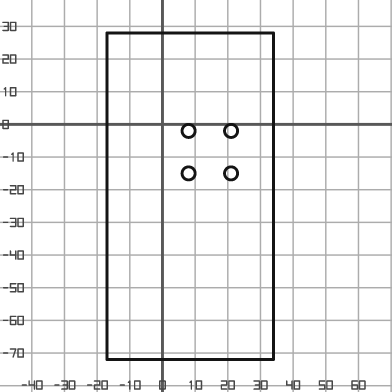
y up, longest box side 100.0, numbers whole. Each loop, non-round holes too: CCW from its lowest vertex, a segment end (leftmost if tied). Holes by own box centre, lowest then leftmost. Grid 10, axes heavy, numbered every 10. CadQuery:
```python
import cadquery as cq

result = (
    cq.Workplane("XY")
    .moveTo(-17.0, -72.0)
    .lineTo(34.0, -72.0)
    .lineTo(34.0, 28.0)
    .lineTo(-17.0, 28.0)
    .close()
    .moveTo(8.0, -15.0)
    .circle(2.0)
    .moveTo(21.0, -15.0)
    .circle(2.0)
    .moveTo(8.0, -2.0)
    .circle(2.0)
    .moveTo(21.0, -2.0)
    .circle(2.0)
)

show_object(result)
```